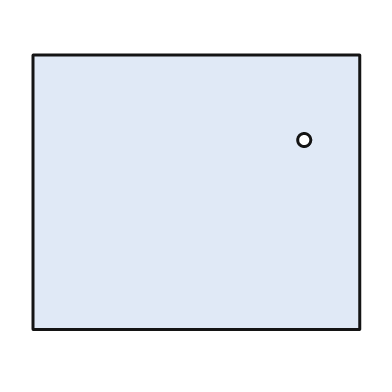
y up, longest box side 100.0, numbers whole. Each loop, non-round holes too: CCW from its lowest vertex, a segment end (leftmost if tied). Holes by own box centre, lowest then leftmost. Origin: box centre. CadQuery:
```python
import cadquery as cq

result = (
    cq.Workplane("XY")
    .moveTo(-50.0, -42.0)
    .lineTo(50.0, -42.0)
    .lineTo(50.0, 42.0)
    .lineTo(-50.0, 42.0)
    .close()
    .moveTo(33.0, 16.0)
    .circle(2.0)
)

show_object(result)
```